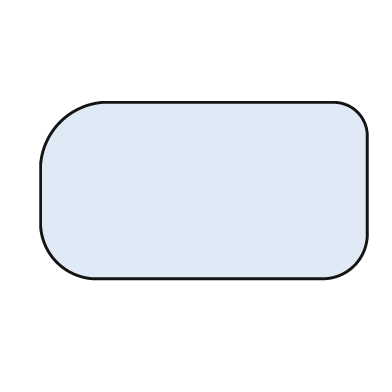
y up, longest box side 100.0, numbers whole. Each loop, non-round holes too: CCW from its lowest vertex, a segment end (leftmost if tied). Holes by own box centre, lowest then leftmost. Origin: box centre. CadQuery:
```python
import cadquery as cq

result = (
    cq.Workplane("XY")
    .moveTo(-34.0, -27.0)
    .lineTo(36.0, -27.0)
    .threePointArc((46.0, -23.0), (50.0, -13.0))
    .lineTo(50.0, 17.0)
    .threePointArc((47.0, 24.0), (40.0, 27.0))
    .lineTo(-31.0, 27.0)
    .threePointArc((-44.0, 21.0), (-50.0, 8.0))
    .lineTo(-50.0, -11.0)
    .threePointArc((-45.0, -22.0), (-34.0, -27.0))
    .close()
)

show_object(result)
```